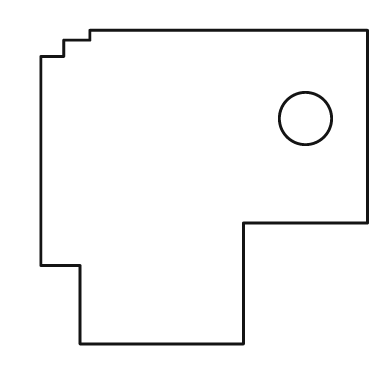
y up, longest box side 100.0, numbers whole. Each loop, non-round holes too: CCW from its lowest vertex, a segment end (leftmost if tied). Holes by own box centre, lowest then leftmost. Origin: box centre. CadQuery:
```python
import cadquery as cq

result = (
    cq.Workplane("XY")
    .moveTo(-38.0, -48.0)
    .lineTo(12.0, -48.0)
    .lineTo(12.0, -11.0)
    .lineTo(50.0, -11.0)
    .lineTo(50.0, 48.0)
    .lineTo(-35.0, 48.0)
    .lineTo(-35.0, 45.0)
    .lineTo(-43.0, 45.0)
    .lineTo(-43.0, 40.0)
    .lineTo(-50.0, 40.0)
    .lineTo(-50.0, -24.0)
    .lineTo(-38.0, -24.0)
    .close()
    .moveTo(31.0, 21.0)
    .circle(8.0)
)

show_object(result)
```